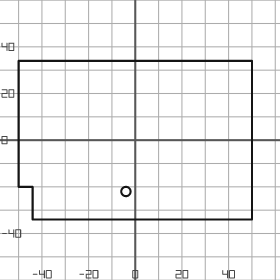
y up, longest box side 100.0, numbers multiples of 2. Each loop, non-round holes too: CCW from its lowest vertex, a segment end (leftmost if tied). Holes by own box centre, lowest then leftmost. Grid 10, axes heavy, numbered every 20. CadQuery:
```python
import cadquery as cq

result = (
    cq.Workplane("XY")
    .moveTo(-44.0, -34.0)
    .lineTo(50.0, -34.0)
    .lineTo(50.0, 34.0)
    .lineTo(-50.0, 34.0)
    .lineTo(-50.0, -20.0)
    .lineTo(-44.0, -20.0)
    .close()
    .moveTo(-4.0, -22.0)
    .circle(2.0)
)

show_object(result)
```